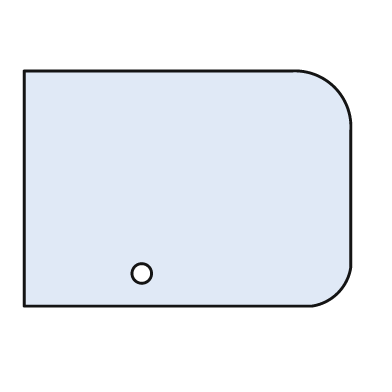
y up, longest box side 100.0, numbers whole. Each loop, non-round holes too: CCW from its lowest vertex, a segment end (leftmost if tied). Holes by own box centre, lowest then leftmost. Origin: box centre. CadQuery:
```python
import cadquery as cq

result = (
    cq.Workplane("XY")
    .moveTo(-50.0, -36.0)
    .lineTo(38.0, -36.0)
    .threePointArc((46.0, -32.0), (50.0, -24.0))
    .lineTo(50.0, 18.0)
    .threePointArc((45.0, 31.0), (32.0, 36.0))
    .lineTo(-50.0, 36.0)
    .close()
    .moveTo(-14.0, -26.0)
    .circle(3.0)
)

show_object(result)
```